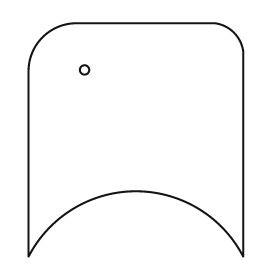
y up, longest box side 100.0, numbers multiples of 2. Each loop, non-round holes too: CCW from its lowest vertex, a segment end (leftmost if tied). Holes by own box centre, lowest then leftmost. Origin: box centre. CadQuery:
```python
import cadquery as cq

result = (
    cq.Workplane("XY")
    .moveTo(-46.0, -50.0)
    .threePointArc((0.0, -22.0), (46.0, -50.0))
    .lineTo(46.0, 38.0)
    .threePointArc((42.0, 46.0), (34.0, 50.0))
    .lineTo(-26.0, 50.0)
    .threePointArc((-40.0, 44.0), (-46.0, 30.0))
    .close()
    .moveTo(-22.0, 30.0)
    .circle(2.0)
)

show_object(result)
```